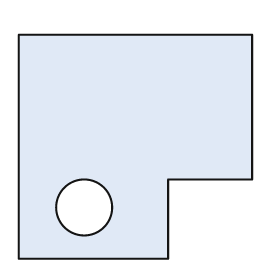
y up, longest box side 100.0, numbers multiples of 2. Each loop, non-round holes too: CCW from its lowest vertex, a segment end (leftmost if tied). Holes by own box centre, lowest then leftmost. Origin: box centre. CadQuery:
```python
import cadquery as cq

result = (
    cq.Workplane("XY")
    .moveTo(-50.0, -48.0)
    .lineTo(14.0, -48.0)
    .lineTo(14.0, -14.0)
    .lineTo(50.0, -14.0)
    .lineTo(50.0, 48.0)
    .lineTo(-50.0, 48.0)
    .close()
    .moveTo(-22.0, -26.0)
    .circle(12.0)
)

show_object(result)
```